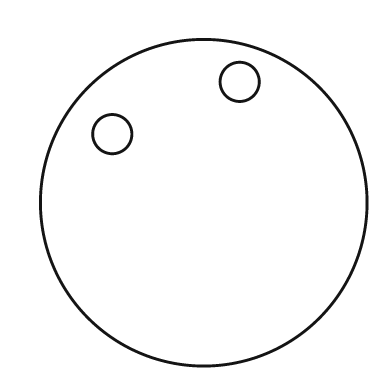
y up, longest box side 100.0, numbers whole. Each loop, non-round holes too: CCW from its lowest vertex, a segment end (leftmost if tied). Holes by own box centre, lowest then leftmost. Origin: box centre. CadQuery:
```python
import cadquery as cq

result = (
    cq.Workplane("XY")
    .moveTo(0.0, 0.0)
    .circle(50.0)
    .moveTo(-28.0, 21.0)
    .circle(6.0)
    .moveTo(11.0, 37.0)
    .circle(6.0)
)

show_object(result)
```